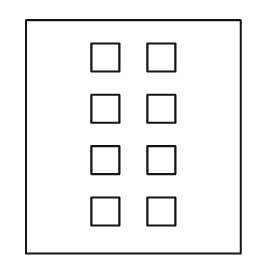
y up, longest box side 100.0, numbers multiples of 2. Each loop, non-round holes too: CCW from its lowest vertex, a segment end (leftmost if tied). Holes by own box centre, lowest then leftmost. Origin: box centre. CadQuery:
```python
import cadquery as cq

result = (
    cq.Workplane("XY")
    .moveTo(-46.0, -50.0)
    .lineTo(46.0, -50.0)
    .lineTo(46.0, 50.0)
    .lineTo(-46.0, 50.0)
    .close()
    .moveTo(-18.0, -38.0)
    .lineTo(-6.0, -38.0)
    .lineTo(-6.0, -26.0)
    .lineTo(-18.0, -26.0)
    .close()
    .moveTo(6.0, -38.0)
    .lineTo(18.0, -38.0)
    .lineTo(18.0, -26.0)
    .lineTo(6.0, -26.0)
    .close()
    .moveTo(-18.0, -16.0)
    .lineTo(-6.0, -16.0)
    .lineTo(-6.0, -4.0)
    .lineTo(-18.0, -4.0)
    .close()
    .moveTo(6.0, -16.0)
    .lineTo(18.0, -16.0)
    .lineTo(18.0, -4.0)
    .lineTo(6.0, -4.0)
    .close()
    .moveTo(-18.0, 6.0)
    .lineTo(-6.0, 6.0)
    .lineTo(-6.0, 18.0)
    .lineTo(-18.0, 18.0)
    .close()
    .moveTo(6.0, 6.0)
    .lineTo(18.0, 6.0)
    .lineTo(18.0, 18.0)
    .lineTo(6.0, 18.0)
    .close()
    .moveTo(-18.0, 28.0)
    .lineTo(-6.0, 28.0)
    .lineTo(-6.0, 40.0)
    .lineTo(-18.0, 40.0)
    .close()
    .moveTo(6.0, 28.0)
    .lineTo(18.0, 28.0)
    .lineTo(18.0, 40.0)
    .lineTo(6.0, 40.0)
    .close()
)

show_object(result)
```